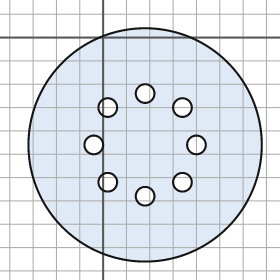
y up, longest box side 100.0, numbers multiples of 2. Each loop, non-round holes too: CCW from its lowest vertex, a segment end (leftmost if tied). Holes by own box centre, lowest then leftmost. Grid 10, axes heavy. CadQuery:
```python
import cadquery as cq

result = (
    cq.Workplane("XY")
    .moveTo(18.0, -46.0)
    .circle(50.0)
    .moveTo(18.0, -68.0)
    .circle(4.0)
    .moveTo(2.0, -62.0)
    .circle(4.0)
    .moveTo(34.0, -62.0)
    .circle(4.0)
    .moveTo(-4.0, -46.0)
    .circle(4.0)
    .moveTo(40.0, -46.0)
    .circle(4.0)
    .moveTo(2.0, -30.0)
    .circle(4.0)
    .moveTo(34.0, -30.0)
    .circle(4.0)
    .moveTo(18.0, -24.0)
    .circle(4.0)
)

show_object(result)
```